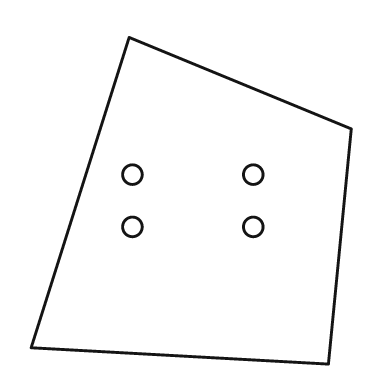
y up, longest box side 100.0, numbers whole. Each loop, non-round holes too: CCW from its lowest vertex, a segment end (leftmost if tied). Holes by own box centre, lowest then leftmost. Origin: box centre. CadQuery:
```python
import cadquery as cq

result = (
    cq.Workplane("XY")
    .moveTo(42.0, -50.0)
    .lineTo(49.0, 22.0)
    .lineTo(-19.0, 50.0)
    .lineTo(-49.0, -45.0)
    .close()
    .moveTo(-18.0, -8.0)
    .circle(3.0)
    .moveTo(19.0, -8.0)
    .circle(3.0)
    .moveTo(-18.0, 8.0)
    .circle(3.0)
    .moveTo(19.0, 8.0)
    .circle(3.0)
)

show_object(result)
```